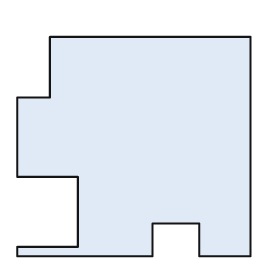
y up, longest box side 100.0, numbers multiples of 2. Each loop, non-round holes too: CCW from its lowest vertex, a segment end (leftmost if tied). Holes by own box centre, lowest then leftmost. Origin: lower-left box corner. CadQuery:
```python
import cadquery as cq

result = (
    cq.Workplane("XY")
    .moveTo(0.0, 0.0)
    .lineTo(58.0, 0.0)
    .lineTo(58.0, 14.0)
    .lineTo(78.0, 14.0)
    .lineTo(78.0, 0.0)
    .lineTo(100.0, 0.0)
    .lineTo(100.0, 94.0)
    .lineTo(14.0, 94.0)
    .lineTo(14.0, 68.0)
    .lineTo(0.0, 68.0)
    .lineTo(0.0, 34.0)
    .lineTo(26.0, 34.0)
    .lineTo(26.0, 4.0)
    .lineTo(0.0, 4.0)
    .close()
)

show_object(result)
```